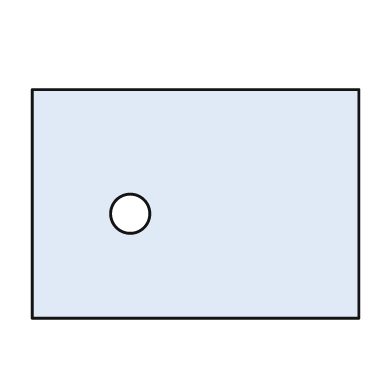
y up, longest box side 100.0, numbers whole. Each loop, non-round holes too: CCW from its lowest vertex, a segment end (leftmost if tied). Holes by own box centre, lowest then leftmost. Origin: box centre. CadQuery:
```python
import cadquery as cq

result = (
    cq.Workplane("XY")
    .moveTo(-50.0, -35.0)
    .lineTo(50.0, -35.0)
    .lineTo(50.0, 35.0)
    .lineTo(-50.0, 35.0)
    .close()
    .moveTo(-20.0, -3.0)
    .circle(6.0)
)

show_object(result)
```